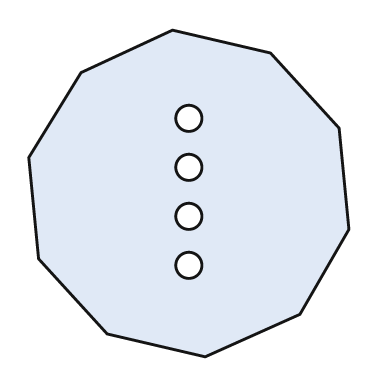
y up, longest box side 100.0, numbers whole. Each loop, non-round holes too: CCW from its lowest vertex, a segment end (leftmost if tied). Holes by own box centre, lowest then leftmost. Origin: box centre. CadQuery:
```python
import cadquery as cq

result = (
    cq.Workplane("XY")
    .moveTo(5.0, -50.0)
    .lineTo(34.0, -37.0)
    .lineTo(49.0, -11.0)
    .lineTo(46.0, 20.0)
    .lineTo(25.0, 43.0)
    .lineTo(-5.0, 50.0)
    .lineTo(-33.0, 37.0)
    .lineTo(-49.0, 11.0)
    .lineTo(-46.0, -20.0)
    .lineTo(-25.0, -43.0)
    .close()
    .moveTo(0.0, -22.0)
    .circle(4.0)
    .moveTo(0.0, -7.0)
    .circle(4.0)
    .moveTo(0.0, 8.0)
    .circle(4.0)
    .moveTo(0.0, 23.0)
    .circle(4.0)
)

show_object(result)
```